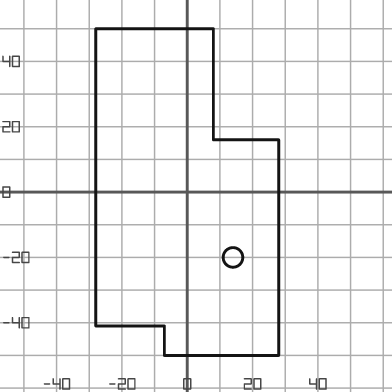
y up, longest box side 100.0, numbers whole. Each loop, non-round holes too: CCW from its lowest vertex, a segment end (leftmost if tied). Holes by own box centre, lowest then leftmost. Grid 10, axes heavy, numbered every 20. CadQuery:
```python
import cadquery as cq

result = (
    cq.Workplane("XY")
    .moveTo(-7.0, -50.0)
    .lineTo(28.0, -50.0)
    .lineTo(28.0, 16.0)
    .lineTo(8.0, 16.0)
    .lineTo(8.0, 50.0)
    .lineTo(-28.0, 50.0)
    .lineTo(-28.0, -41.0)
    .lineTo(-7.0, -41.0)
    .close()
    .moveTo(14.0, -20.0)
    .circle(3.0)
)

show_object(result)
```